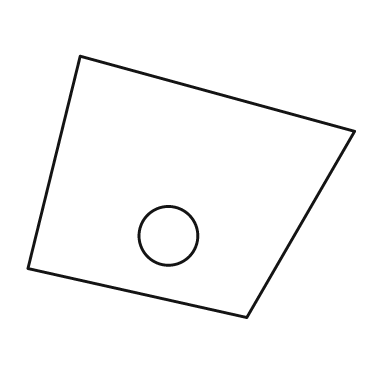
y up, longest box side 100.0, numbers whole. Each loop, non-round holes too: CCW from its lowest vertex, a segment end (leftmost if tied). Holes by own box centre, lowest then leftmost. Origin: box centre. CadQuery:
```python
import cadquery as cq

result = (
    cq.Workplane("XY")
    .moveTo(17.0, -40.0)
    .lineTo(50.0, 17.0)
    .lineTo(-34.0, 40.0)
    .lineTo(-50.0, -25.0)
    .close()
    .moveTo(-7.0, -15.0)
    .circle(9.0)
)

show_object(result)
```